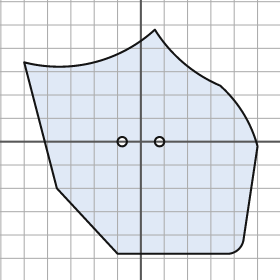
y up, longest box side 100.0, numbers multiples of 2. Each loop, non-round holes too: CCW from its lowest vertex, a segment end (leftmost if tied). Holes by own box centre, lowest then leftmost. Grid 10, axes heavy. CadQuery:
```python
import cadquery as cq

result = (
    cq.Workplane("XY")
    .moveTo(-10.0, -48.0)
    .lineTo(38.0, -48.0)
    .threePointArc((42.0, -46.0), (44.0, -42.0))
    .lineTo(50.0, -2.0)
    .threePointArc((44.0, 12.0), (34.0, 24.0))
    .threePointArc((18.0, 34.0), (6.0, 48.0))
    .threePointArc((-20.0, 34.0), (-50.0, 34.0))
    .lineTo(-36.0, -20.0)
    .close()
    .moveTo(-8.0, 0.0)
    .circle(2.0)
    .moveTo(8.0, 0.0)
    .circle(2.0)
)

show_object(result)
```